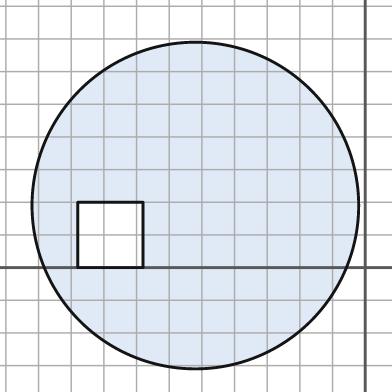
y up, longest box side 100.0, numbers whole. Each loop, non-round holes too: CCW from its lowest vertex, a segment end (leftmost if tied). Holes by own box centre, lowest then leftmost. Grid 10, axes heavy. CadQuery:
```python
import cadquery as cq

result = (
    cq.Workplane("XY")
    .moveTo(-52.0, 19.0)
    .circle(50.0)
    .moveTo(-88.0, 0.0)
    .lineTo(-68.0, 0.0)
    .lineTo(-68.0, 20.0)
    .lineTo(-88.0, 20.0)
    .close()
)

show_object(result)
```